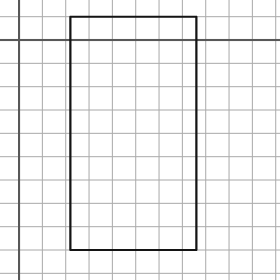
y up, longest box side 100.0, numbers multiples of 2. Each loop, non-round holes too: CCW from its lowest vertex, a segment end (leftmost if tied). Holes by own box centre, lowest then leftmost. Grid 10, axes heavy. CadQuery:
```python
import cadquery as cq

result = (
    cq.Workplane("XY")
    .moveTo(22.0, -90.0)
    .lineTo(76.0, -90.0)
    .lineTo(76.0, 10.0)
    .lineTo(22.0, 10.0)
    .close()
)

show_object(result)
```